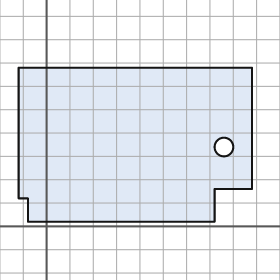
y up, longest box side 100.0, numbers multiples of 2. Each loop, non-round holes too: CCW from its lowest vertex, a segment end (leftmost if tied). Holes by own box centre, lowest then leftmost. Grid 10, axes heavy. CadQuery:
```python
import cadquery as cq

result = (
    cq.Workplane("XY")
    .moveTo(-8.0, 2.0)
    .lineTo(72.0, 2.0)
    .lineTo(72.0, 16.0)
    .lineTo(88.0, 16.0)
    .lineTo(88.0, 68.0)
    .lineTo(-12.0, 68.0)
    .lineTo(-12.0, 12.0)
    .lineTo(-8.0, 12.0)
    .close()
    .moveTo(76.0, 34.0)
    .circle(4.0)
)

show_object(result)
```